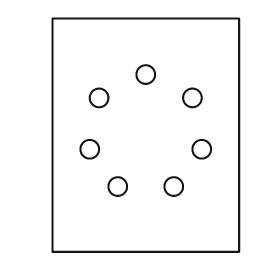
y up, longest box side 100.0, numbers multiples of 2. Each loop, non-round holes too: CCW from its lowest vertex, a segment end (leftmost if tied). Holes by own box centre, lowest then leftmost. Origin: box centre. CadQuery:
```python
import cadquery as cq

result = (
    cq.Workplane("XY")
    .moveTo(-40.0, -50.0)
    .lineTo(40.0, -50.0)
    .lineTo(40.0, 50.0)
    .lineTo(-40.0, 50.0)
    .close()
    .moveTo(-12.0, -22.0)
    .circle(4.0)
    .moveTo(12.0, -22.0)
    .circle(4.0)
    .moveTo(-24.0, -6.0)
    .circle(4.0)
    .moveTo(24.0, -6.0)
    .circle(4.0)
    .moveTo(-20.0, 16.0)
    .circle(4.0)
    .moveTo(20.0, 16.0)
    .circle(4.0)
    .moveTo(0.0, 26.0)
    .circle(4.0)
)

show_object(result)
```